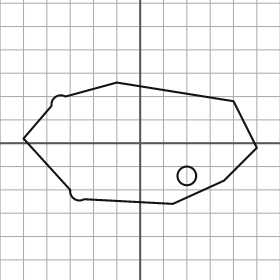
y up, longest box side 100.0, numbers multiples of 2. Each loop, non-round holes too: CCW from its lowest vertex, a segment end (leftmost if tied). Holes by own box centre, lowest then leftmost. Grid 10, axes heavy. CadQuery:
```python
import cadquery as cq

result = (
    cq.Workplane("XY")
    .moveTo(14.0, -26.0)
    .lineTo(36.0, -16.0)
    .lineTo(50.0, -2.0)
    .lineTo(40.0, 18.0)
    .lineTo(-10.0, 26.0)
    .lineTo(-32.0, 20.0)
    .threePointArc((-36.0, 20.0), (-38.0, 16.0))
    .lineTo(-50.0, 2.0)
    .lineTo(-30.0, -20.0)
    .threePointArc((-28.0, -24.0), (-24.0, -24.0))
    .close()
    .moveTo(20.0, -14.0)
    .circle(4.0)
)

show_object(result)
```